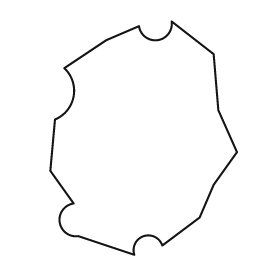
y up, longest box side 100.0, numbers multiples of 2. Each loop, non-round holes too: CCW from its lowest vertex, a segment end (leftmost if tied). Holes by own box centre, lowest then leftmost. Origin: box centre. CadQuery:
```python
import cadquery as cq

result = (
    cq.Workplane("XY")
    .moveTo(-4.0, -50.0)
    .threePointArc((0.0, -42.0), (8.0, -46.0))
    .lineTo(24.0, -34.0)
    .lineTo(30.0, -20.0)
    .lineTo(40.0, -6.0)
    .lineTo(32.0, 12.0)
    .lineTo(30.0, 36.0)
    .lineTo(12.0, 50.0)
    .threePointArc((6.0, 42.0), (-2.0, 48.0))
    .lineTo(-16.0, 42.0)
    .lineTo(-34.0, 30.0)
    .threePointArc((-30.0, 18.0), (-38.0, 8.0))
    .lineTo(-40.0, -14.0)
    .lineTo(-30.0, -28.0)
    .threePointArc((-36.0, -36.0), (-28.0, -42.0))
    .close()
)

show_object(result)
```